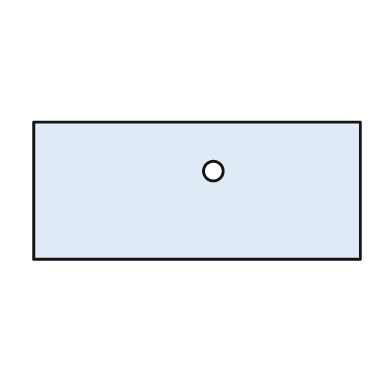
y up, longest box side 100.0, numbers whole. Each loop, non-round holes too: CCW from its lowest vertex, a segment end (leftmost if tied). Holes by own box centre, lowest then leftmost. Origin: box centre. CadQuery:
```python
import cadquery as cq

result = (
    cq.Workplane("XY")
    .moveTo(-50.0, -21.0)
    .lineTo(50.0, -21.0)
    .lineTo(50.0, 21.0)
    .lineTo(-50.0, 21.0)
    .close()
    .moveTo(5.0, 6.0)
    .circle(3.0)
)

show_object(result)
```